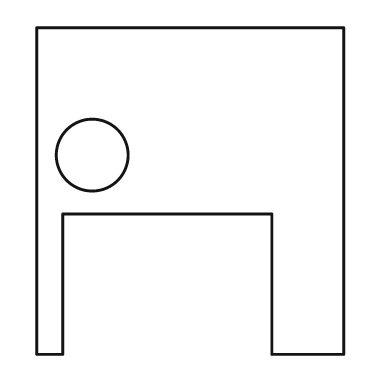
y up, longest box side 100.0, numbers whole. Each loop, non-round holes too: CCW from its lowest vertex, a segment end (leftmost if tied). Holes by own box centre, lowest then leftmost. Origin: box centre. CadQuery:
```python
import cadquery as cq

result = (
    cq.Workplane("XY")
    .moveTo(-47.0, -50.0)
    .lineTo(-39.0, -50.0)
    .lineTo(-39.0, -7.0)
    .lineTo(25.0, -7.0)
    .lineTo(25.0, -50.0)
    .lineTo(47.0, -50.0)
    .lineTo(47.0, 50.0)
    .lineTo(-47.0, 50.0)
    .close()
    .moveTo(-30.0, 11.0)
    .circle(11.0)
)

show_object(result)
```